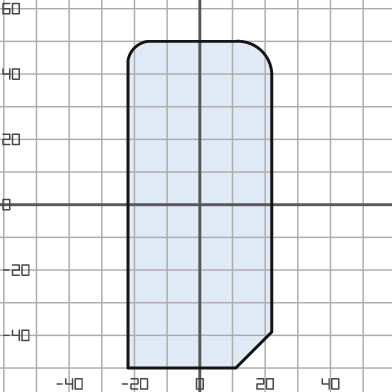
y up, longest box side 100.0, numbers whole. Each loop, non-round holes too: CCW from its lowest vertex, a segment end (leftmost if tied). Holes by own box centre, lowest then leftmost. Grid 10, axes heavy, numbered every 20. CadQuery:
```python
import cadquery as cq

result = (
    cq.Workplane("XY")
    .moveTo(-22.0, -50.0)
    .lineTo(11.0, -50.0)
    .lineTo(22.0, -39.0)
    .lineTo(22.0, 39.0)
    .threePointArc((19.0, 47.0), (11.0, 50.0))
    .lineTo(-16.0, 50.0)
    .threePointArc((-20.0, 48.0), (-22.0, 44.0))
    .close()
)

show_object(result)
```